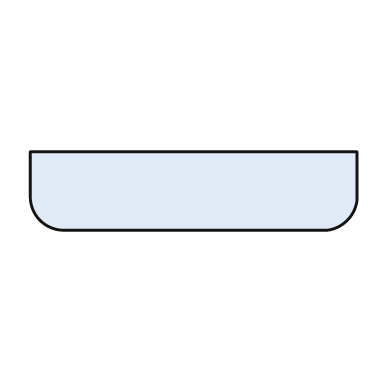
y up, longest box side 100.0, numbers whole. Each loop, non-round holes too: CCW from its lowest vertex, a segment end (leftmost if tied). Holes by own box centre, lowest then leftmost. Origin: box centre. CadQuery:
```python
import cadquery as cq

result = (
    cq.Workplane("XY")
    .moveTo(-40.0, -12.0)
    .lineTo(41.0, -12.0)
    .threePointArc((47.0, -9.0), (50.0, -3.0))
    .lineTo(50.0, 12.0)
    .lineTo(-50.0, 12.0)
    .lineTo(-50.0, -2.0)
    .threePointArc((-47.0, -9.0), (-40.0, -12.0))
    .close()
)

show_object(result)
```